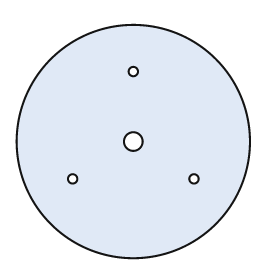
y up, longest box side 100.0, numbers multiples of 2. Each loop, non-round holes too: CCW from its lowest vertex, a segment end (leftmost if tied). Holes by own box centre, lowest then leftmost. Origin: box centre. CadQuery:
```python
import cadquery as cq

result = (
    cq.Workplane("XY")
    .moveTo(0.0, 0.0)
    .circle(50.0)
    .moveTo(-26.0, -16.0)
    .circle(2.0)
    .moveTo(26.0, -16.0)
    .circle(2.0)
    .moveTo(0.0, 0.0)
    .circle(4.0)
    .moveTo(0.0, 30.0)
    .circle(2.0)
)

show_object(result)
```